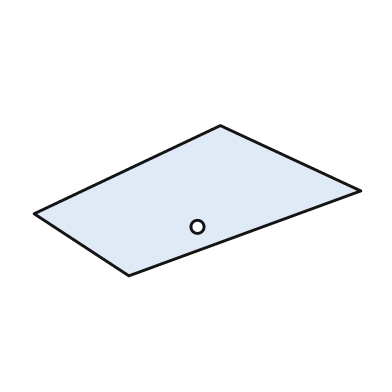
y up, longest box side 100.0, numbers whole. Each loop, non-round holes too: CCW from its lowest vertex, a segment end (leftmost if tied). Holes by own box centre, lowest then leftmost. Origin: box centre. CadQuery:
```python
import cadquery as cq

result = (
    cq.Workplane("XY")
    .moveTo(-21.0, -23.0)
    .lineTo(50.0, 3.0)
    .lineTo(7.0, 23.0)
    .lineTo(-50.0, -4.0)
    .close()
    .moveTo(0.0, -8.0)
    .circle(2.0)
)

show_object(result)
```